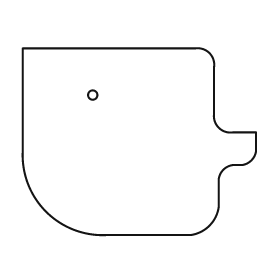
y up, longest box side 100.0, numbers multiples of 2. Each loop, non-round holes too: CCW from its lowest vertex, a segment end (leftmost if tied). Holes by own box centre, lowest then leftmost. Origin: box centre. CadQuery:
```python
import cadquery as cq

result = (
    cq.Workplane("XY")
    .moveTo(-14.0, -40.0)
    .lineTo(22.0, -40.0)
    .threePointArc((30.0, -36.0), (34.0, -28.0))
    .lineTo(34.0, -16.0)
    .threePointArc((36.0, -12.0), (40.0, -10.0))
    .lineTo(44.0, -10.0)
    .threePointArc((48.0, -8.0), (50.0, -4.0))
    .lineTo(50.0, 4.0)
    .lineTo(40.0, 4.0)
    .threePointArc((34.0, 6.0), (32.0, 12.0))
    .lineTo(32.0, 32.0)
    .threePointArc((30.0, 38.0), (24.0, 40.0))
    .lineTo(-50.0, 40.0)
    .lineTo(-50.0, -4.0)
    .threePointArc((-40.0, -30.0), (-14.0, -40.0))
    .close()
    .moveTo(-20.0, 20.0)
    .circle(2.0)
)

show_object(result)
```